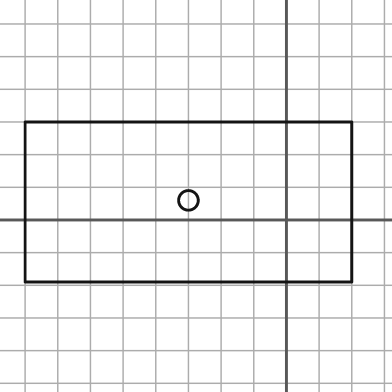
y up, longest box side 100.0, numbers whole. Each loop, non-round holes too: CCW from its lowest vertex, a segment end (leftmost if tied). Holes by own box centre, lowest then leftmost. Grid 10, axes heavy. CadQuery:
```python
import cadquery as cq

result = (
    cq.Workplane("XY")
    .moveTo(-80.0, -19.0)
    .lineTo(20.0, -19.0)
    .lineTo(20.0, 30.0)
    .lineTo(-80.0, 30.0)
    .close()
    .moveTo(-30.0, 6.0)
    .circle(3.0)
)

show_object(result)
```